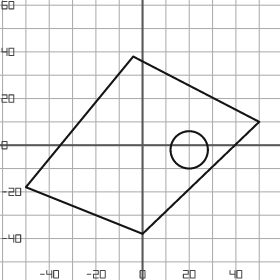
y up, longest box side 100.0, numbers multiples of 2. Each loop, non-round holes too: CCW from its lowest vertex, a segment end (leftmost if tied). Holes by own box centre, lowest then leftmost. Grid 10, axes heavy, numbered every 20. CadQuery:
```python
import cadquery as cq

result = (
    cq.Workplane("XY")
    .moveTo(0.0, -38.0)
    .lineTo(50.0, 10.0)
    .lineTo(-4.0, 38.0)
    .lineTo(-50.0, -18.0)
    .close()
    .moveTo(20.0, -2.0)
    .circle(8.0)
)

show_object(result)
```